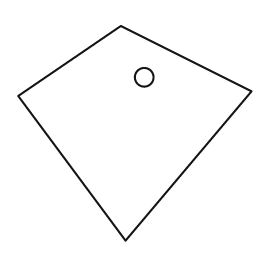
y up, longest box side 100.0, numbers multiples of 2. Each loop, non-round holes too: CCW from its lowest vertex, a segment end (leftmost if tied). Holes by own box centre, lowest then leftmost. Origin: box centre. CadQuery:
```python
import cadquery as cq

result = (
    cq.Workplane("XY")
    .moveTo(-4.0, -46.0)
    .lineTo(50.0, 18.0)
    .lineTo(-6.0, 46.0)
    .lineTo(-50.0, 16.0)
    .close()
    .moveTo(4.0, 24.0)
    .circle(4.0)
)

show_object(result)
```